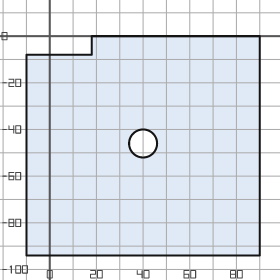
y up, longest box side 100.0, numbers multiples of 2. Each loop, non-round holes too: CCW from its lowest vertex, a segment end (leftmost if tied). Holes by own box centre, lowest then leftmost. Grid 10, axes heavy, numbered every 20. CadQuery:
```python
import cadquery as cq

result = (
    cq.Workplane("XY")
    .moveTo(-10.0, -94.0)
    .lineTo(90.0, -94.0)
    .lineTo(90.0, 0.0)
    .lineTo(18.0, 0.0)
    .lineTo(18.0, -8.0)
    .lineTo(-10.0, -8.0)
    .close()
    .moveTo(40.0, -46.0)
    .circle(6.0)
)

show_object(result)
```